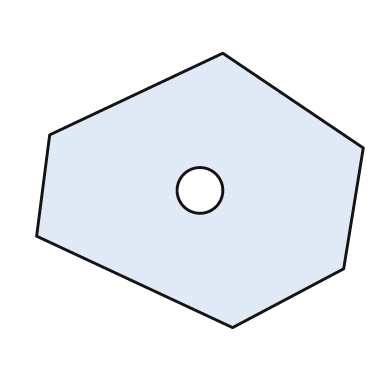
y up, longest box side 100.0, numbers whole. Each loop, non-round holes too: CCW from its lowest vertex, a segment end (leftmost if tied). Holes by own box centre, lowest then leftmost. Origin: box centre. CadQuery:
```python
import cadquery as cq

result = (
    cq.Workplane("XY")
    .moveTo(10.0, -42.0)
    .lineTo(44.0, -24.0)
    .lineTo(50.0, 13.0)
    .lineTo(7.0, 42.0)
    .lineTo(-46.0, 17.0)
    .lineTo(-50.0, -14.0)
    .close()
    .moveTo(0.0, 0.0)
    .circle(7.0)
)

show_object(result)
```